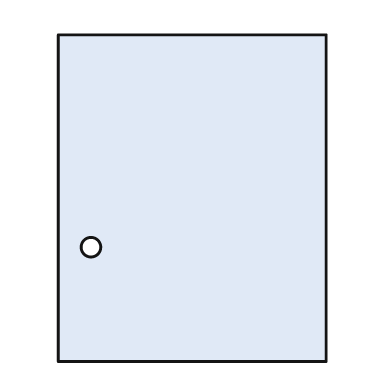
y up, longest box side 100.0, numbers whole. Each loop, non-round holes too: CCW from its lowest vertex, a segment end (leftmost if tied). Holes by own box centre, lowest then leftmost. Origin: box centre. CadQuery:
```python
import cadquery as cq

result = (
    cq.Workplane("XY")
    .moveTo(-41.0, -50.0)
    .lineTo(41.0, -50.0)
    .lineTo(41.0, 50.0)
    .lineTo(-41.0, 50.0)
    .close()
    .moveTo(-31.0, -15.0)
    .circle(3.0)
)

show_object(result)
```